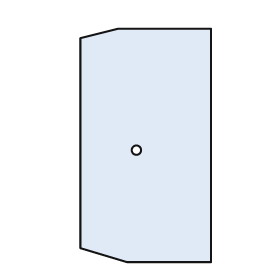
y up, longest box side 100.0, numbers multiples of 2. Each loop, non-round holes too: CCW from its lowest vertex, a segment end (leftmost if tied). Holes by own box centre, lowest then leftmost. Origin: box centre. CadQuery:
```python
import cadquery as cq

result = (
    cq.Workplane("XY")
    .moveTo(-8.0, -50.0)
    .lineTo(28.0, -50.0)
    .lineTo(28.0, 50.0)
    .lineTo(-12.0, 50.0)
    .lineTo(-28.0, 46.0)
    .lineTo(-28.0, -44.0)
    .close()
    .moveTo(-4.0, -2.0)
    .circle(2.0)
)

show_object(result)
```